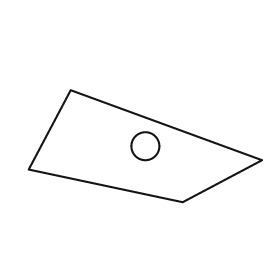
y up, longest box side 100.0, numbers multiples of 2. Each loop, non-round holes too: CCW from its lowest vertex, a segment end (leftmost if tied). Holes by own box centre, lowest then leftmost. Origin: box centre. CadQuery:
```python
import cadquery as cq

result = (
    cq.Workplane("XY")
    .moveTo(16.0, -24.0)
    .lineTo(50.0, -6.0)
    .lineTo(-32.0, 24.0)
    .lineTo(-50.0, -10.0)
    .close()
    .moveTo(0.0, 0.0)
    .circle(6.0)
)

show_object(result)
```